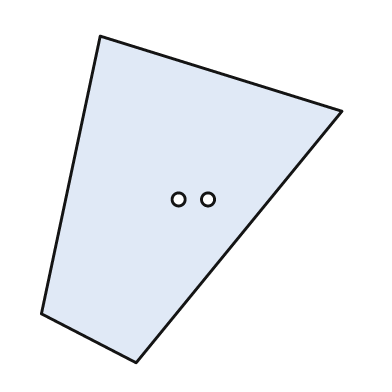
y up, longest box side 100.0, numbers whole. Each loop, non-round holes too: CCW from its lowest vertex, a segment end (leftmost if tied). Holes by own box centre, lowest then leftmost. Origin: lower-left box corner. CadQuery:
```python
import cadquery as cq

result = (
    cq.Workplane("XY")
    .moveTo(29.0, 0.0)
    .lineTo(92.0, 77.0)
    .lineTo(18.0, 100.0)
    .lineTo(0.0, 15.0)
    .close()
    .moveTo(42.0, 50.0)
    .circle(2.0)
    .moveTo(51.0, 50.0)
    .circle(2.0)
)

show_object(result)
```